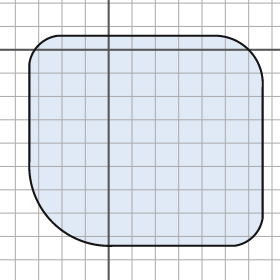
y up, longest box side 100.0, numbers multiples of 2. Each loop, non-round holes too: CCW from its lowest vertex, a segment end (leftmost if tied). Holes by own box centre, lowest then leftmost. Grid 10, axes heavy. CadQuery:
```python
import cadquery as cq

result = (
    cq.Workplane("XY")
    .moveTo(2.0, -84.0)
    .lineTo(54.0, -84.0)
    .threePointArc((62.0, -80.0), (66.0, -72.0))
    .lineTo(66.0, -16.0)
    .threePointArc((60.0, 0.0), (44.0, 6.0))
    .lineTo(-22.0, 6.0)
    .threePointArc((-30.0, 2.0), (-34.0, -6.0))
    .lineTo(-34.0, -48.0)
    .threePointArc((-24.0, -74.0), (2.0, -84.0))
    .close()
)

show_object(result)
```